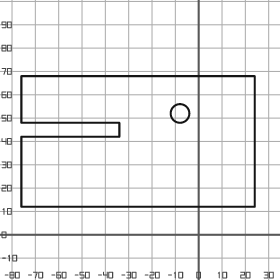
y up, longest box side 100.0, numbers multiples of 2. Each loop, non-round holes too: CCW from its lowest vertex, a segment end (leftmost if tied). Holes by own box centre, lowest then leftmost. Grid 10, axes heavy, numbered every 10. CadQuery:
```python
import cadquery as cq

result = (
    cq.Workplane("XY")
    .moveTo(-76.0, 12.0)
    .lineTo(24.0, 12.0)
    .lineTo(24.0, 68.0)
    .lineTo(-76.0, 68.0)
    .lineTo(-76.0, 48.0)
    .lineTo(-34.0, 48.0)
    .lineTo(-34.0, 42.0)
    .lineTo(-76.0, 42.0)
    .close()
    .moveTo(-8.0, 52.0)
    .circle(4.0)
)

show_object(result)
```